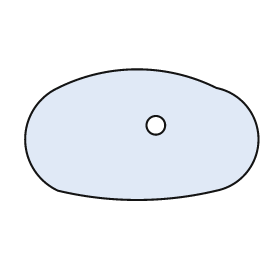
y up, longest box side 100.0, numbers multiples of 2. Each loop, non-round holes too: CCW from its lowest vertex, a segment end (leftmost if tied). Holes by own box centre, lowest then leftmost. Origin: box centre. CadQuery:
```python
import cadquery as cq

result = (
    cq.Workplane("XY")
    .moveTo(-36.0, -24.0)
    .threePointArc((-2.0, -28.0), (32.0, -24.0))
    .threePointArc((50.0, -2.0), (32.0, 20.0))
    .threePointArc((-2.0, 28.0), (-36.0, 20.0))
    .threePointArc((-50.0, -2.0), (-36.0, -24.0))
    .close()
    .moveTo(6.0, 4.0)
    .circle(4.0)
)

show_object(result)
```